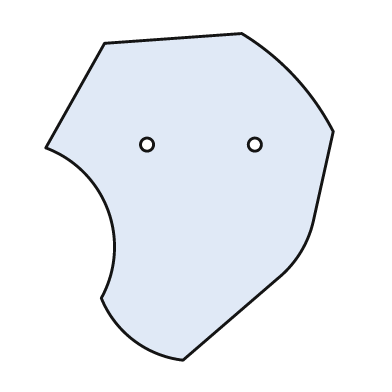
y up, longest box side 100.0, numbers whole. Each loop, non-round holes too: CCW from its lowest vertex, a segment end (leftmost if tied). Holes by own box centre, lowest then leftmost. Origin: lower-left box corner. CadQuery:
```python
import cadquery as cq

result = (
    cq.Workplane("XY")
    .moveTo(42.0, 0.0)
    .lineTo(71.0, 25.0)
    .threePointArc((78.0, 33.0), (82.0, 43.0))
    .lineTo(88.0, 70.0)
    .threePointArc((76.0, 87.0), (60.0, 100.0))
    .lineTo(18.0, 97.0)
    .lineTo(0.0, 65.0)
    .threePointArc((19.0, 46.0), (17.0, 19.0))
    .threePointArc((27.0, 6.0), (42.0, 0.0))
    .close()
    .moveTo(31.0, 66.0)
    .circle(2.0)
    .moveTo(64.0, 66.0)
    .circle(2.0)
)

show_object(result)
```